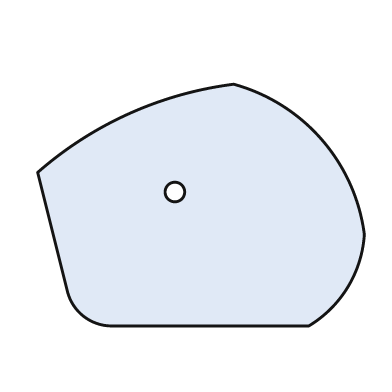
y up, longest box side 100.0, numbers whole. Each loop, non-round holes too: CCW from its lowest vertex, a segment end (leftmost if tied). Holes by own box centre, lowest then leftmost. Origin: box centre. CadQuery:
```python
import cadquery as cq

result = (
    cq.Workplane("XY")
    .moveTo(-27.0, -37.0)
    .lineTo(33.0, -37.0)
    .threePointArc((45.0, -25.0), (50.0, -9.0))
    .threePointArc((37.0, 20.0), (10.0, 37.0))
    .threePointArc((-22.0, 28.0), (-50.0, 10.0))
    .lineTo(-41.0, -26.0)
    .threePointArc((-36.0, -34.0), (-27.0, -37.0))
    .close()
    .moveTo(-8.0, 4.0)
    .circle(3.0)
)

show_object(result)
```